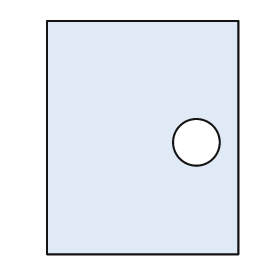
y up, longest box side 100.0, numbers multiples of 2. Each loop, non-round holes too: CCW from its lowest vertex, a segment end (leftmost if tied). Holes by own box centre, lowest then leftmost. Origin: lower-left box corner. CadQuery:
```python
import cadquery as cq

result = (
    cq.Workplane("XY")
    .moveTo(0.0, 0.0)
    .lineTo(82.0, 0.0)
    .lineTo(82.0, 100.0)
    .lineTo(0.0, 100.0)
    .close()
    .moveTo(64.0, 48.0)
    .circle(10.0)
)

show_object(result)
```